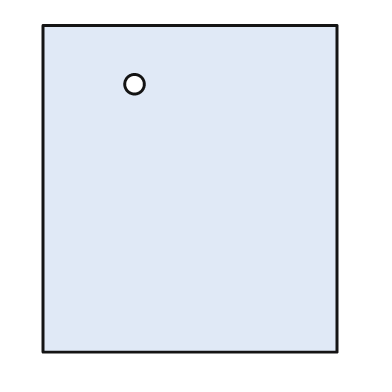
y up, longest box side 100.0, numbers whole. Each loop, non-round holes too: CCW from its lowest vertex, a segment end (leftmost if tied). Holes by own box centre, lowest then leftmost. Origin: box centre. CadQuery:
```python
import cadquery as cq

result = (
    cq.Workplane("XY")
    .moveTo(-45.0, -50.0)
    .lineTo(45.0, -50.0)
    .lineTo(45.0, 50.0)
    .lineTo(-45.0, 50.0)
    .close()
    .moveTo(-17.0, 32.0)
    .circle(3.0)
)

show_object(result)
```